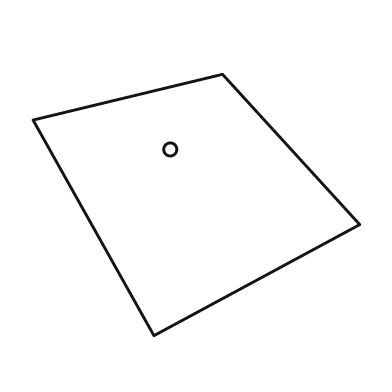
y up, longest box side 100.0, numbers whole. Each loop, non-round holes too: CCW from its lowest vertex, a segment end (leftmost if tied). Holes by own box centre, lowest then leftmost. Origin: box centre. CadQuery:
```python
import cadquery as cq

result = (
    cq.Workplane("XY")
    .moveTo(-13.0, -40.0)
    .lineTo(50.0, -6.0)
    .lineTo(8.0, 40.0)
    .lineTo(-50.0, 26.0)
    .close()
    .moveTo(-8.0, 17.0)
    .circle(2.0)
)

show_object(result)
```